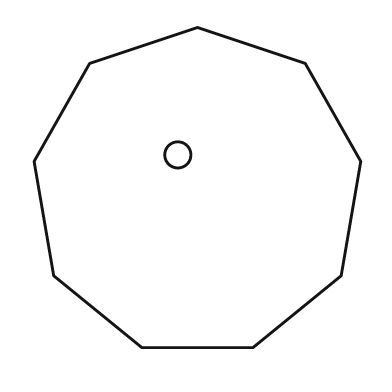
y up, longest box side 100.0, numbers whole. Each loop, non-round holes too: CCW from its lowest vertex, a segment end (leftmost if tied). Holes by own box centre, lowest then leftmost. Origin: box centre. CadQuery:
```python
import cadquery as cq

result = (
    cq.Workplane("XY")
    .moveTo(-17.0, -49.0)
    .lineTo(17.0, -49.0)
    .lineTo(44.0, -27.0)
    .lineTo(50.0, 8.0)
    .lineTo(33.0, 38.0)
    .lineTo(0.0, 49.0)
    .lineTo(-33.0, 38.0)
    .lineTo(-50.0, 8.0)
    .lineTo(-44.0, -27.0)
    .close()
    .moveTo(-6.0, 10.0)
    .circle(4.0)
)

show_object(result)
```